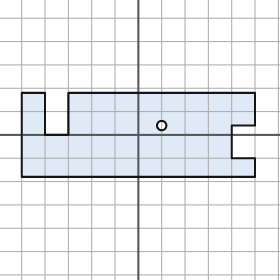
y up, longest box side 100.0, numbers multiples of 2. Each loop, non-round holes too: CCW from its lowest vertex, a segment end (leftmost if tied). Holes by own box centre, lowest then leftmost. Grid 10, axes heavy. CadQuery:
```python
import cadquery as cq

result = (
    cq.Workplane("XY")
    .moveTo(-50.0, -18.0)
    .lineTo(50.0, -18.0)
    .lineTo(50.0, -10.0)
    .lineTo(40.0, -10.0)
    .lineTo(40.0, 4.0)
    .lineTo(50.0, 4.0)
    .lineTo(50.0, 18.0)
    .lineTo(-30.0, 18.0)
    .lineTo(-30.0, 0.0)
    .lineTo(-40.0, 0.0)
    .lineTo(-40.0, 18.0)
    .lineTo(-50.0, 18.0)
    .close()
    .moveTo(10.0, 4.0)
    .circle(2.0)
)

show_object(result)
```